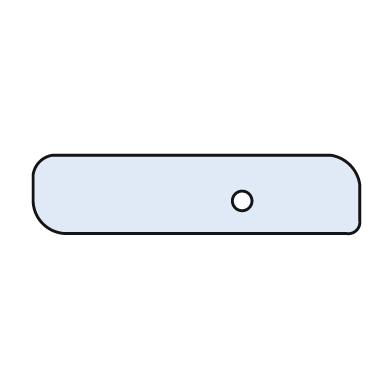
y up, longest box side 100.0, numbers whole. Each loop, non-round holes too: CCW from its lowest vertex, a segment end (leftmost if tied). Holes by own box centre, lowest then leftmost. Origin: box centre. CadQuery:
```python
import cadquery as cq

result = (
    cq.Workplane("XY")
    .moveTo(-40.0, -12.0)
    .lineTo(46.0, -12.0)
    .threePointArc((49.0, -11.0), (50.0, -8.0))
    .lineTo(50.0, 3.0)
    .threePointArc((47.0, 9.0), (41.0, 12.0))
    .lineTo(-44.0, 12.0)
    .threePointArc((-48.0, 10.0), (-50.0, 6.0))
    .lineTo(-50.0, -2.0)
    .threePointArc((-47.0, -9.0), (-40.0, -12.0))
    .close()
    .moveTo(14.0, -2.0)
    .circle(3.0)
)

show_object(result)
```